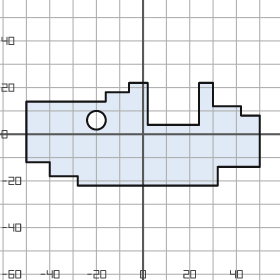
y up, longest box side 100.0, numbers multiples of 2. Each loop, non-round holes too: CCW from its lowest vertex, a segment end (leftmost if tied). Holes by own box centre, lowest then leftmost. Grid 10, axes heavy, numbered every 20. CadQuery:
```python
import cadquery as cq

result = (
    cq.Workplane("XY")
    .moveTo(-28.0, -22.0)
    .lineTo(32.0, -22.0)
    .lineTo(32.0, -14.0)
    .lineTo(50.0, -14.0)
    .lineTo(50.0, 8.0)
    .lineTo(42.0, 8.0)
    .lineTo(42.0, 12.0)
    .lineTo(30.0, 12.0)
    .lineTo(30.0, 22.0)
    .lineTo(24.0, 22.0)
    .lineTo(24.0, 4.0)
    .lineTo(2.0, 4.0)
    .lineTo(2.0, 22.0)
    .lineTo(-6.0, 22.0)
    .lineTo(-6.0, 18.0)
    .lineTo(-16.0, 18.0)
    .lineTo(-16.0, 14.0)
    .lineTo(-50.0, 14.0)
    .lineTo(-50.0, -12.0)
    .lineTo(-40.0, -12.0)
    .lineTo(-40.0, -18.0)
    .lineTo(-28.0, -18.0)
    .close()
    .moveTo(-20.0, 6.0)
    .circle(4.0)
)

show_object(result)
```